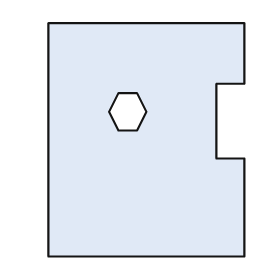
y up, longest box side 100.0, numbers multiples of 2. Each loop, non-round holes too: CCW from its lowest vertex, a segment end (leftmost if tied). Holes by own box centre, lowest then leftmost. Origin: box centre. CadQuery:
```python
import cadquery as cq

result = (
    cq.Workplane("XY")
    .moveTo(-42.0, -50.0)
    .lineTo(42.0, -50.0)
    .lineTo(42.0, -8.0)
    .lineTo(30.0, -8.0)
    .lineTo(30.0, 24.0)
    .lineTo(42.0, 24.0)
    .lineTo(42.0, 50.0)
    .lineTo(-42.0, 50.0)
    .close()
    .moveTo(-12.0, 4.0)
    .lineTo(-4.0, 4.0)
    .lineTo(0.0, 12.0)
    .lineTo(-4.0, 20.0)
    .lineTo(-12.0, 20.0)
    .lineTo(-16.0, 12.0)
    .close()
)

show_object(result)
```